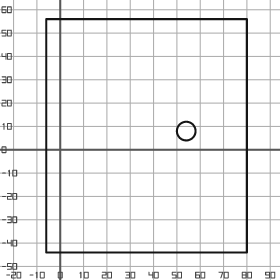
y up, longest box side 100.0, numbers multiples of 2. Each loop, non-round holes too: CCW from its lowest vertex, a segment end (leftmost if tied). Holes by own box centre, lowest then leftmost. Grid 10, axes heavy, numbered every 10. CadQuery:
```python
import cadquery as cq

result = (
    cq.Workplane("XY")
    .moveTo(-6.0, -44.0)
    .lineTo(80.0, -44.0)
    .lineTo(80.0, 56.0)
    .lineTo(-6.0, 56.0)
    .close()
    .moveTo(54.0, 8.0)
    .circle(4.0)
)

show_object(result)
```